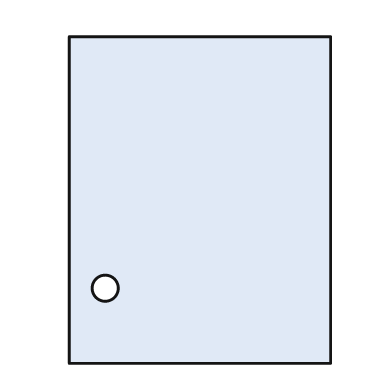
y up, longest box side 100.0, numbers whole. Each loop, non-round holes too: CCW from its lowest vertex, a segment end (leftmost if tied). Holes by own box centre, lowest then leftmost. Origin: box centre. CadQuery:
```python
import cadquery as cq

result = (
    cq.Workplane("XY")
    .moveTo(-40.0, -50.0)
    .lineTo(40.0, -50.0)
    .lineTo(40.0, 50.0)
    .lineTo(-40.0, 50.0)
    .close()
    .moveTo(-29.0, -27.0)
    .circle(4.0)
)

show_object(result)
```